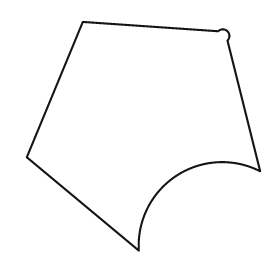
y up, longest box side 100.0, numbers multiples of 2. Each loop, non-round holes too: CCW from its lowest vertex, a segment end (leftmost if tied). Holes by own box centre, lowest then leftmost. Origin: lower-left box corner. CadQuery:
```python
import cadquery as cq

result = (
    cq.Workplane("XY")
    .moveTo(48.0, 0.0)
    .threePointArc((64.0, 32.0), (100.0, 34.0))
    .lineTo(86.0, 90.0)
    .threePointArc((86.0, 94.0), (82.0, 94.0))
    .lineTo(24.0, 98.0)
    .lineTo(0.0, 40.0)
    .close()
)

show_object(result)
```